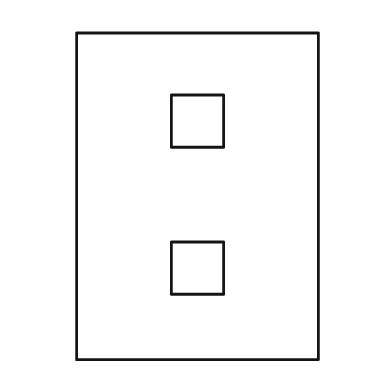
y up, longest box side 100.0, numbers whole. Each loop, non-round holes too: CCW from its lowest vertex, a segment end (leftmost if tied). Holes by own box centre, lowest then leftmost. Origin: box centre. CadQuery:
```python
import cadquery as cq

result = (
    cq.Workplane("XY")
    .moveTo(-37.0, -50.0)
    .lineTo(37.0, -50.0)
    .lineTo(37.0, 50.0)
    .lineTo(-37.0, 50.0)
    .close()
    .moveTo(-8.0, -30.0)
    .lineTo(8.0, -30.0)
    .lineTo(8.0, -14.0)
    .lineTo(-8.0, -14.0)
    .close()
    .moveTo(-8.0, 15.0)
    .lineTo(8.0, 15.0)
    .lineTo(8.0, 31.0)
    .lineTo(-8.0, 31.0)
    .close()
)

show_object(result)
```